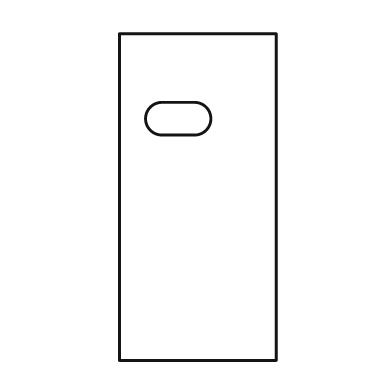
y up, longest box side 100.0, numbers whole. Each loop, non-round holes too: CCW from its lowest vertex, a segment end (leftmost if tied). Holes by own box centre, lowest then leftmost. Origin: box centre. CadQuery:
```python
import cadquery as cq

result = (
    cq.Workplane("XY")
    .moveTo(-24.0, -50.0)
    .lineTo(24.0, -50.0)
    .lineTo(24.0, 50.0)
    .lineTo(-24.0, 50.0)
    .close()
    .moveTo(-11.0, 19.0)
    .lineTo(-1.0, 19.0)
    .threePointArc((4.0, 24.0), (-1.0, 29.0))
    .lineTo(-11.0, 29.0)
    .threePointArc((-16.0, 24.0), (-11.0, 19.0))
    .close()
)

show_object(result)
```